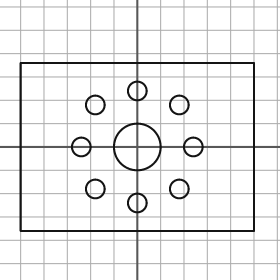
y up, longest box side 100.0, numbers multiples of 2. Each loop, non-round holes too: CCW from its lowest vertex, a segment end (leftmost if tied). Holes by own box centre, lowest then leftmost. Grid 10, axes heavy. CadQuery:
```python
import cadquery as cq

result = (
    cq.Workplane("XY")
    .moveTo(-50.0, -36.0)
    .lineTo(50.0, -36.0)
    .lineTo(50.0, 36.0)
    .lineTo(-50.0, 36.0)
    .close()
    .moveTo(0.0, -24.0)
    .circle(4.0)
    .moveTo(-18.0, -18.0)
    .circle(4.0)
    .moveTo(18.0, -18.0)
    .circle(4.0)
    .moveTo(-24.0, 0.0)
    .circle(4.0)
    .moveTo(0.0, 0.0)
    .circle(10.0)
    .moveTo(24.0, 0.0)
    .circle(4.0)
    .moveTo(-18.0, 18.0)
    .circle(4.0)
    .moveTo(18.0, 18.0)
    .circle(4.0)
    .moveTo(0.0, 24.0)
    .circle(4.0)
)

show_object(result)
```